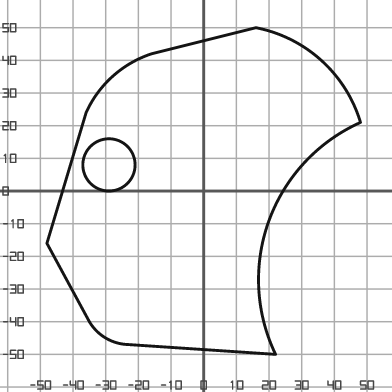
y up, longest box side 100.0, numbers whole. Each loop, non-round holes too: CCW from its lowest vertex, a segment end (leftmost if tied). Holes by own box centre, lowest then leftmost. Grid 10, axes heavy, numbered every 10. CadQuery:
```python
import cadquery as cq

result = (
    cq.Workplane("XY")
    .moveTo(22.0, -50.0)
    .threePointArc((20.0, -9.0), (48.0, 21.0))
    .threePointArc((36.0, 40.0), (16.0, 50.0))
    .lineTo(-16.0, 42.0)
    .threePointArc((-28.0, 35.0), (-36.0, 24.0))
    .lineTo(-48.0, -16.0)
    .lineTo(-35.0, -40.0)
    .threePointArc((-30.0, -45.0), (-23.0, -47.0))
    .close()
    .moveTo(-29.0, 8.0)
    .circle(8.0)
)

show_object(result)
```